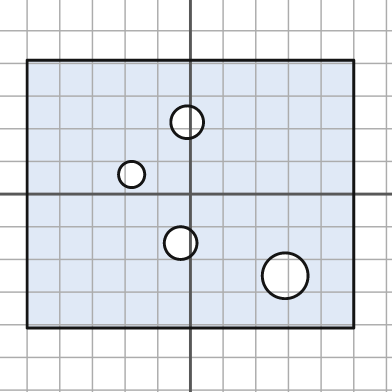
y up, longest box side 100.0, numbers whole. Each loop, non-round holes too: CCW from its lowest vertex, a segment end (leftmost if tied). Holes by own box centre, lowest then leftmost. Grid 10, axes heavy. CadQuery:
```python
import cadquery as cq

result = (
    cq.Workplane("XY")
    .moveTo(-50.0, -41.0)
    .lineTo(50.0, -41.0)
    .lineTo(50.0, 41.0)
    .lineTo(-50.0, 41.0)
    .close()
    .moveTo(29.0, -25.0)
    .circle(7.0)
    .moveTo(-3.0, -15.0)
    .circle(5.0)
    .moveTo(-18.0, 6.0)
    .circle(4.0)
    .moveTo(-1.0, 22.0)
    .circle(5.0)
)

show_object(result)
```